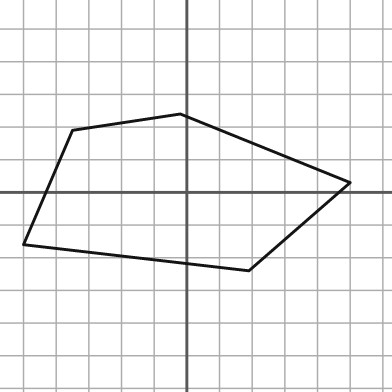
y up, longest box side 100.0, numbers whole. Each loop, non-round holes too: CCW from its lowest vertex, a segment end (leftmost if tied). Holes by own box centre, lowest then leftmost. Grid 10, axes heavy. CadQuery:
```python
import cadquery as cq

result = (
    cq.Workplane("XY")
    .moveTo(19.0, -24.0)
    .lineTo(50.0, 3.0)
    .lineTo(-2.0, 24.0)
    .lineTo(-35.0, 19.0)
    .lineTo(-50.0, -16.0)
    .close()
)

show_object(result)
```